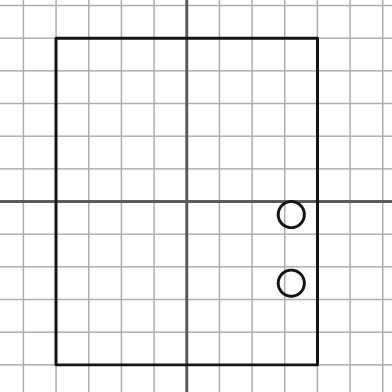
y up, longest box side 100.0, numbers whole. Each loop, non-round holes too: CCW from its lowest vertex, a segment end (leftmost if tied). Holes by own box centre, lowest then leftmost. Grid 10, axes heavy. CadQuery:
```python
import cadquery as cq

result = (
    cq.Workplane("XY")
    .moveTo(-40.0, -50.0)
    .lineTo(40.0, -50.0)
    .lineTo(40.0, 50.0)
    .lineTo(-40.0, 50.0)
    .close()
    .moveTo(32.0, -25.0)
    .circle(4.0)
    .moveTo(32.0, -4.0)
    .circle(4.0)
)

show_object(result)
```